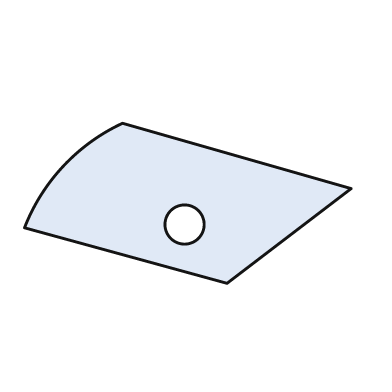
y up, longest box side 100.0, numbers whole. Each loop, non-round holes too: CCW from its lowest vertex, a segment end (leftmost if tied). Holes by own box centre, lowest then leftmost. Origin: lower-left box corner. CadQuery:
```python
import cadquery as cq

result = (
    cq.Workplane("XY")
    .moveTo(62.0, 0.0)
    .lineTo(100.0, 29.0)
    .lineTo(30.0, 49.0)
    .threePointArc((12.0, 36.0), (0.0, 17.0))
    .close()
    .moveTo(49.0, 18.0)
    .circle(6.0)
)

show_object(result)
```